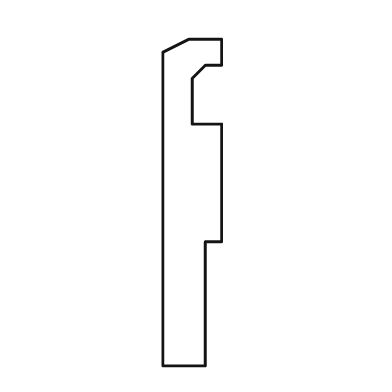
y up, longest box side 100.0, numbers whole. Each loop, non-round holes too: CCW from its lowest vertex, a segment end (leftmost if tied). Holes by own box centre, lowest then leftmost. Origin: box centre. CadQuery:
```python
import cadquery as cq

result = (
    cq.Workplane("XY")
    .moveTo(-9.0, -50.0)
    .lineTo(4.0, -50.0)
    .lineTo(4.0, -12.0)
    .lineTo(9.0, -12.0)
    .lineTo(9.0, 24.0)
    .lineTo(0.0, 24.0)
    .lineTo(0.0, 38.0)
    .lineTo(4.0, 42.0)
    .lineTo(9.0, 42.0)
    .lineTo(9.0, 50.0)
    .lineTo(-1.0, 50.0)
    .lineTo(-9.0, 46.0)
    .close()
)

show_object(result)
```